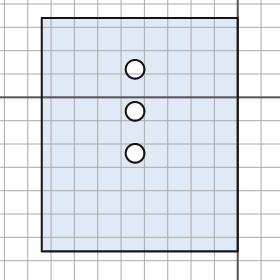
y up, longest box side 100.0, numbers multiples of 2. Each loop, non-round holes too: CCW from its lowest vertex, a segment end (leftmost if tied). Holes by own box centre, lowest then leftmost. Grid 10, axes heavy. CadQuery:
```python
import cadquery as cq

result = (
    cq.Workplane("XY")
    .moveTo(-84.0, -66.0)
    .lineTo(0.0, -66.0)
    .lineTo(0.0, 34.0)
    .lineTo(-84.0, 34.0)
    .close()
    .moveTo(-44.0, -24.0)
    .circle(4.0)
    .moveTo(-44.0, -6.0)
    .circle(4.0)
    .moveTo(-44.0, 12.0)
    .circle(4.0)
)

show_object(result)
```